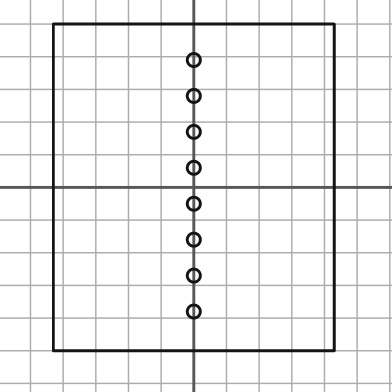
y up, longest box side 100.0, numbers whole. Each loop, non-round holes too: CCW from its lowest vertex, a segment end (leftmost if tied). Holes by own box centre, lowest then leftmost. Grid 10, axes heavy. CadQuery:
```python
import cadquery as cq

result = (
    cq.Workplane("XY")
    .moveTo(-43.0, -50.0)
    .lineTo(43.0, -50.0)
    .lineTo(43.0, 50.0)
    .lineTo(-43.0, 50.0)
    .close()
    .moveTo(0.0, -38.0)
    .circle(2.0)
    .moveTo(0.0, -27.0)
    .circle(2.0)
    .moveTo(0.0, -16.0)
    .circle(2.0)
    .moveTo(0.0, -5.0)
    .circle(2.0)
    .moveTo(0.0, 6.0)
    .circle(2.0)
    .moveTo(0.0, 17.0)
    .circle(2.0)
    .moveTo(0.0, 28.0)
    .circle(2.0)
    .moveTo(0.0, 39.0)
    .circle(2.0)
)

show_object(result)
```